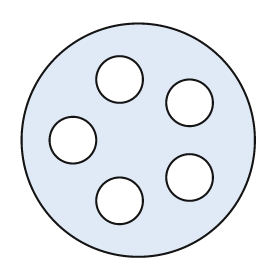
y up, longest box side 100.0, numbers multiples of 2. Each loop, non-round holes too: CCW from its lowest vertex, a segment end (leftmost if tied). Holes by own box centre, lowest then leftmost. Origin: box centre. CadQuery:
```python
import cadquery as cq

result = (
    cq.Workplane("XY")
    .moveTo(0.0, 0.0)
    .circle(50.0)
    .moveTo(-8.0, -26.0)
    .circle(10.0)
    .moveTo(22.0, -16.0)
    .circle(10.0)
    .moveTo(-28.0, 0.0)
    .circle(10.0)
    .moveTo(22.0, 16.0)
    .circle(10.0)
    .moveTo(-8.0, 26.0)
    .circle(10.0)
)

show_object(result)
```